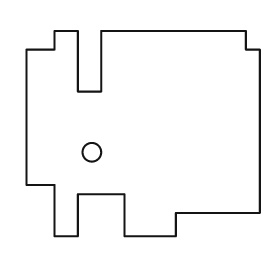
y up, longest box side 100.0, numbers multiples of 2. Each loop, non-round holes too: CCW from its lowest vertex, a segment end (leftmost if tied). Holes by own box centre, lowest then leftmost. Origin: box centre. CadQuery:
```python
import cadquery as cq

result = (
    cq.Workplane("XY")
    .moveTo(-38.0, -44.0)
    .lineTo(-28.0, -44.0)
    .lineTo(-28.0, -26.0)
    .lineTo(-8.0, -26.0)
    .lineTo(-8.0, -44.0)
    .lineTo(14.0, -44.0)
    .lineTo(14.0, -34.0)
    .lineTo(50.0, -34.0)
    .lineTo(50.0, 36.0)
    .lineTo(44.0, 36.0)
    .lineTo(44.0, 44.0)
    .lineTo(-18.0, 44.0)
    .lineTo(-18.0, 18.0)
    .lineTo(-28.0, 18.0)
    .lineTo(-28.0, 44.0)
    .lineTo(-38.0, 44.0)
    .lineTo(-38.0, 36.0)
    .lineTo(-50.0, 36.0)
    .lineTo(-50.0, -22.0)
    .lineTo(-38.0, -22.0)
    .close()
    .moveTo(-22.0, -8.0)
    .circle(4.0)
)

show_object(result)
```